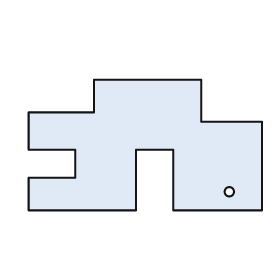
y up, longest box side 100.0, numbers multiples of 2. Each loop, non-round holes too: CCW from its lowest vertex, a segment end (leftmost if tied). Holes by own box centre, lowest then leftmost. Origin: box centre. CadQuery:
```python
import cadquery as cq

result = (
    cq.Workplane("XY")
    .moveTo(-50.0, -28.0)
    .lineTo(-4.0, -28.0)
    .lineTo(-4.0, -2.0)
    .lineTo(12.0, -2.0)
    .lineTo(12.0, -28.0)
    .lineTo(50.0, -28.0)
    .lineTo(50.0, 10.0)
    .lineTo(24.0, 10.0)
    .lineTo(24.0, 28.0)
    .lineTo(-22.0, 28.0)
    .lineTo(-22.0, 14.0)
    .lineTo(-50.0, 14.0)
    .lineTo(-50.0, -2.0)
    .lineTo(-30.0, -2.0)
    .lineTo(-30.0, -14.0)
    .lineTo(-50.0, -14.0)
    .close()
    .moveTo(36.0, -20.0)
    .circle(2.0)
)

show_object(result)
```